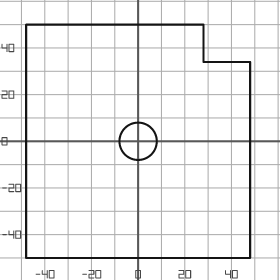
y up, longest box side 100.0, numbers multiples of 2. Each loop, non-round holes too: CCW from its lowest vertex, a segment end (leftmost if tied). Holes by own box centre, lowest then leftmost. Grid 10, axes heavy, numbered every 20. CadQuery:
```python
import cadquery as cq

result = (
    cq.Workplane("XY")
    .moveTo(-48.0, -50.0)
    .lineTo(48.0, -50.0)
    .lineTo(48.0, 34.0)
    .lineTo(28.0, 34.0)
    .lineTo(28.0, 50.0)
    .lineTo(-48.0, 50.0)
    .close()
    .moveTo(0.0, 0.0)
    .circle(8.0)
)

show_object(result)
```